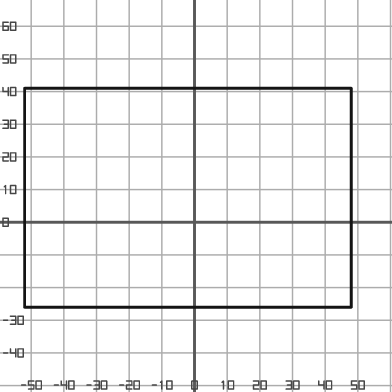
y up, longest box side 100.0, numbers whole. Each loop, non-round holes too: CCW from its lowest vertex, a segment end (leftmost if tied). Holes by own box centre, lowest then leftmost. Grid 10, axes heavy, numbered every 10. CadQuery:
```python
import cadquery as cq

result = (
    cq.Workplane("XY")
    .moveTo(-52.0, -26.0)
    .lineTo(48.0, -26.0)
    .lineTo(48.0, 41.0)
    .lineTo(-52.0, 41.0)
    .close()
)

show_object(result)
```